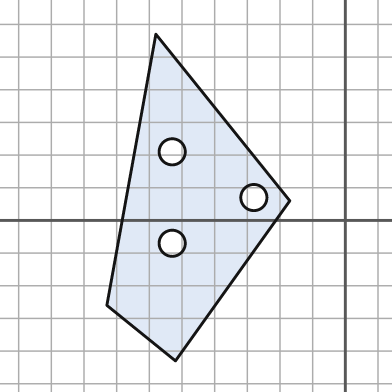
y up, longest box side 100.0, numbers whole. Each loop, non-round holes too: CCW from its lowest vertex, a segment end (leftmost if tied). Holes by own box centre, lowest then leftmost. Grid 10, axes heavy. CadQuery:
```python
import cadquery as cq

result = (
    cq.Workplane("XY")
    .moveTo(-52.0, -43.0)
    .lineTo(-17.0, 6.0)
    .lineTo(-58.0, 57.0)
    .lineTo(-73.0, -26.0)
    .close()
    .moveTo(-53.0, -7.0)
    .circle(4.0)
    .moveTo(-28.0, 7.0)
    .circle(4.0)
    .moveTo(-53.0, 21.0)
    .circle(4.0)
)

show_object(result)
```